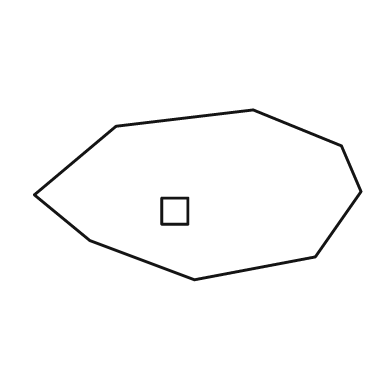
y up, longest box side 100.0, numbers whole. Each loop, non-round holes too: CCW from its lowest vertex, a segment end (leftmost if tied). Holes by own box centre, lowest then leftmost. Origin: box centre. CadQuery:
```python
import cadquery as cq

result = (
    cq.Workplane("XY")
    .moveTo(-1.0, -26.0)
    .lineTo(36.0, -19.0)
    .lineTo(50.0, 1.0)
    .lineTo(44.0, 15.0)
    .lineTo(17.0, 26.0)
    .lineTo(-25.0, 21.0)
    .lineTo(-50.0, 0.0)
    .lineTo(-33.0, -14.0)
    .close()
    .moveTo(-11.0, -9.0)
    .lineTo(-3.0, -9.0)
    .lineTo(-3.0, -1.0)
    .lineTo(-11.0, -1.0)
    .close()
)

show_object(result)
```